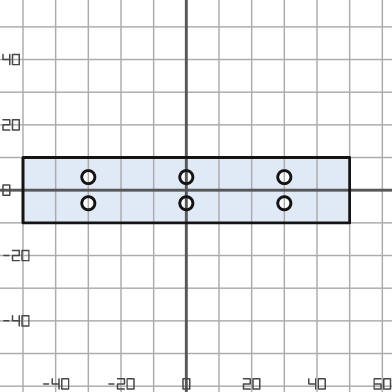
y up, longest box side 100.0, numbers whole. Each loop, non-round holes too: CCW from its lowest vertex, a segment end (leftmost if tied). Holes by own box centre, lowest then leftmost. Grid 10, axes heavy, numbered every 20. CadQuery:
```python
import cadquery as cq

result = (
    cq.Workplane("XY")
    .moveTo(-50.0, -10.0)
    .lineTo(50.0, -10.0)
    .lineTo(50.0, 10.0)
    .lineTo(-50.0, 10.0)
    .close()
    .moveTo(-30.0, -4.0)
    .circle(2.0)
    .moveTo(0.0, -4.0)
    .circle(2.0)
    .moveTo(30.0, -4.0)
    .circle(2.0)
    .moveTo(-30.0, 4.0)
    .circle(2.0)
    .moveTo(0.0, 4.0)
    .circle(2.0)
    .moveTo(30.0, 4.0)
    .circle(2.0)
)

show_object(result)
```